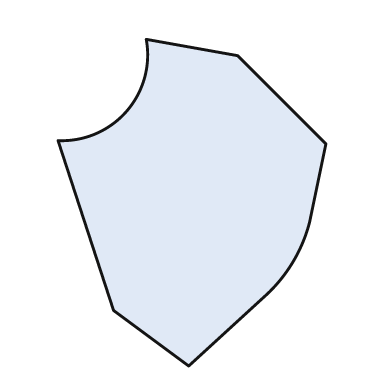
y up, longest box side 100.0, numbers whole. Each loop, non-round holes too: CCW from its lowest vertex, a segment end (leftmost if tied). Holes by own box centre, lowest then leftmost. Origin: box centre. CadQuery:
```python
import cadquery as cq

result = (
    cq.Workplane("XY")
    .moveTo(-1.0, -50.0)
    .lineTo(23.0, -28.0)
    .threePointArc((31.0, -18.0), (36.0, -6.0))
    .lineTo(41.0, 18.0)
    .lineTo(14.0, 45.0)
    .lineTo(-14.0, 50.0)
    .threePointArc((-20.0, 28.0), (-41.0, 19.0))
    .lineTo(-24.0, -33.0)
    .close()
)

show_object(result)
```